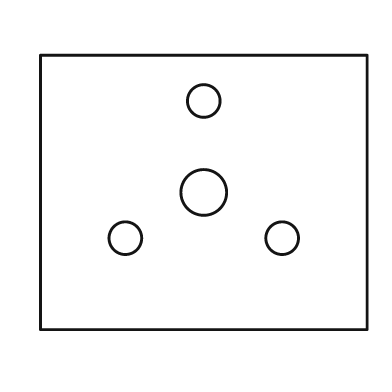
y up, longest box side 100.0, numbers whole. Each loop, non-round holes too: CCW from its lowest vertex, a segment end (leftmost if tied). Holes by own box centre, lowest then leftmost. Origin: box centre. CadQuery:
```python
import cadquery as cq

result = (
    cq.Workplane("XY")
    .moveTo(-50.0, -42.0)
    .lineTo(50.0, -42.0)
    .lineTo(50.0, 42.0)
    .lineTo(-50.0, 42.0)
    .close()
    .moveTo(-24.0, -14.0)
    .circle(5.0)
    .moveTo(24.0, -14.0)
    .circle(5.0)
    .moveTo(0.0, 0.0)
    .circle(7.0)
    .moveTo(0.0, 28.0)
    .circle(5.0)
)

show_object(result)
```